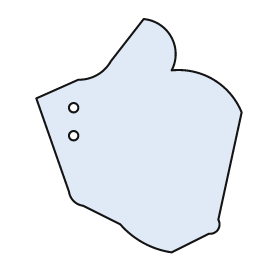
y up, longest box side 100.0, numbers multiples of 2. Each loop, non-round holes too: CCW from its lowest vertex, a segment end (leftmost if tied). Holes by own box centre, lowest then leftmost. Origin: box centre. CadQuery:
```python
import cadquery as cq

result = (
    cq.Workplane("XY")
    .moveTo(14.0, -50.0)
    .lineTo(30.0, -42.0)
    .threePointArc((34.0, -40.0), (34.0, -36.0))
    .lineTo(44.0, 10.0)
    .threePointArc((32.0, 24.0), (14.0, 28.0))
    .threePointArc((14.0, 42.0), (2.0, 50.0))
    .lineTo(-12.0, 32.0)
    .threePointArc((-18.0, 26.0), (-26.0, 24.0))
    .lineTo(-44.0, 16.0)
    .lineTo(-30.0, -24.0)
    .threePointArc((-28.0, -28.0), (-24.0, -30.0))
    .lineTo(-8.0, -38.0)
    .threePointArc((2.0, -46.0), (14.0, -50.0))
    .close()
    .moveTo(-28.0, 0.0)
    .circle(2.0)
    .moveTo(-28.0, 12.0)
    .circle(2.0)
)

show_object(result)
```